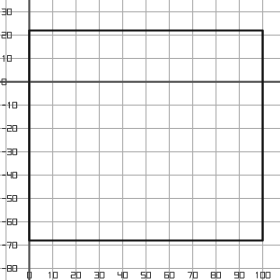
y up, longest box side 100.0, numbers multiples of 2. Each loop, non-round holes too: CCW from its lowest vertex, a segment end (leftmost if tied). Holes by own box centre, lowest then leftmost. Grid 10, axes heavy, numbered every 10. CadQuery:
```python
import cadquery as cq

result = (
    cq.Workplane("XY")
    .moveTo(0.0, -68.0)
    .lineTo(100.0, -68.0)
    .lineTo(100.0, 22.0)
    .lineTo(0.0, 22.0)
    .close()
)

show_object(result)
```